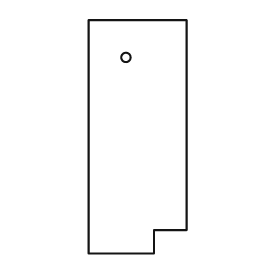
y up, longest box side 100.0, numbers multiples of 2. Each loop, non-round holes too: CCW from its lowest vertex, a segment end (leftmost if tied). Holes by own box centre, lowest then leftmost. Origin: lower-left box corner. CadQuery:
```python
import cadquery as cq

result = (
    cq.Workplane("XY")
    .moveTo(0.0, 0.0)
    .lineTo(28.0, 0.0)
    .lineTo(28.0, 10.0)
    .lineTo(42.0, 10.0)
    .lineTo(42.0, 100.0)
    .lineTo(0.0, 100.0)
    .close()
    .moveTo(16.0, 84.0)
    .circle(2.0)
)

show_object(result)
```